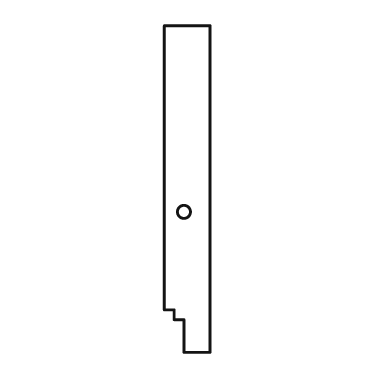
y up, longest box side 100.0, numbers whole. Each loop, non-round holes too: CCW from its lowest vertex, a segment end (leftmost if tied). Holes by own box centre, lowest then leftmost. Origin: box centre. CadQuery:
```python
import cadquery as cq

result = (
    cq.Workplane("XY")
    .moveTo(-1.0, -50.0)
    .lineTo(7.0, -50.0)
    .lineTo(7.0, 50.0)
    .lineTo(-7.0, 50.0)
    .lineTo(-7.0, -37.0)
    .lineTo(-4.0, -37.0)
    .lineTo(-4.0, -40.0)
    .lineTo(-1.0, -40.0)
    .close()
    .moveTo(-1.0, -7.0)
    .circle(2.0)
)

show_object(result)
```